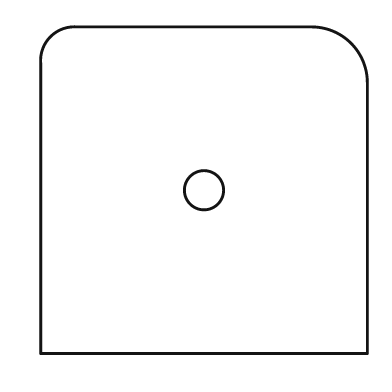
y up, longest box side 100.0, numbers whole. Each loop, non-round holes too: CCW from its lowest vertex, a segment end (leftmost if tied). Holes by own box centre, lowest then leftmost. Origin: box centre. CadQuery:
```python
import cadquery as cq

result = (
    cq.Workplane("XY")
    .moveTo(-50.0, -50.0)
    .lineTo(50.0, -50.0)
    .lineTo(50.0, 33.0)
    .threePointArc((45.0, 45.0), (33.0, 50.0))
    .lineTo(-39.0, 50.0)
    .threePointArc((-47.0, 47.0), (-50.0, 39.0))
    .close()
    .moveTo(0.0, 0.0)
    .circle(6.0)
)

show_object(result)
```